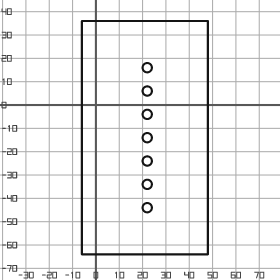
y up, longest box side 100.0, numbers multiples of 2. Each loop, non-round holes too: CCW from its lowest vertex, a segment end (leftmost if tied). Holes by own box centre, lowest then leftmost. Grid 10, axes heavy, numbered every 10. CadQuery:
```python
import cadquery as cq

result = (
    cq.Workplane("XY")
    .moveTo(-6.0, -64.0)
    .lineTo(48.0, -64.0)
    .lineTo(48.0, 36.0)
    .lineTo(-6.0, 36.0)
    .close()
    .moveTo(22.0, -44.0)
    .circle(2.0)
    .moveTo(22.0, -34.0)
    .circle(2.0)
    .moveTo(22.0, -24.0)
    .circle(2.0)
    .moveTo(22.0, -14.0)
    .circle(2.0)
    .moveTo(22.0, -4.0)
    .circle(2.0)
    .moveTo(22.0, 6.0)
    .circle(2.0)
    .moveTo(22.0, 16.0)
    .circle(2.0)
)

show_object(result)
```